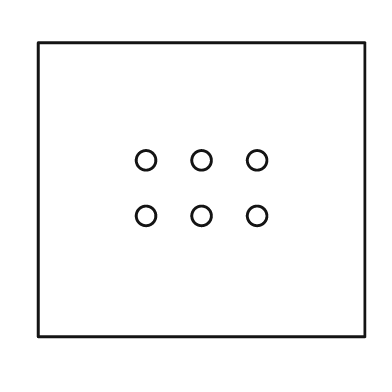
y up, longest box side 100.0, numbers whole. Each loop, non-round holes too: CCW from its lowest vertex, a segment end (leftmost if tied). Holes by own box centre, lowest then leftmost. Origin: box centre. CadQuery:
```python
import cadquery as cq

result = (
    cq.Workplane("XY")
    .moveTo(-50.0, -45.0)
    .lineTo(50.0, -45.0)
    .lineTo(50.0, 45.0)
    .lineTo(-50.0, 45.0)
    .close()
    .moveTo(-17.0, -8.0)
    .circle(3.0)
    .moveTo(0.0, -8.0)
    .circle(3.0)
    .moveTo(17.0, -8.0)
    .circle(3.0)
    .moveTo(-17.0, 9.0)
    .circle(3.0)
    .moveTo(0.0, 9.0)
    .circle(3.0)
    .moveTo(17.0, 9.0)
    .circle(3.0)
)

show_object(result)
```